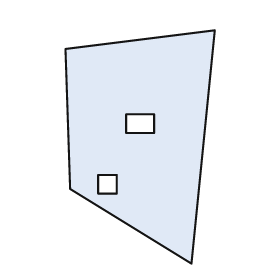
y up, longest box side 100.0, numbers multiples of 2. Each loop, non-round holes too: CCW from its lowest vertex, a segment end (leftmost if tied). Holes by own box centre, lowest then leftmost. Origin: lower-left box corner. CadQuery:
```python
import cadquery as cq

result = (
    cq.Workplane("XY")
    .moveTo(54.0, 0.0)
    .lineTo(64.0, 100.0)
    .lineTo(0.0, 92.0)
    .lineTo(2.0, 32.0)
    .close()
    .moveTo(14.0, 30.0)
    .lineTo(22.0, 30.0)
    .lineTo(22.0, 38.0)
    .lineTo(14.0, 38.0)
    .close()
    .moveTo(26.0, 56.0)
    .lineTo(38.0, 56.0)
    .lineTo(38.0, 64.0)
    .lineTo(26.0, 64.0)
    .close()
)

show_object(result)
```